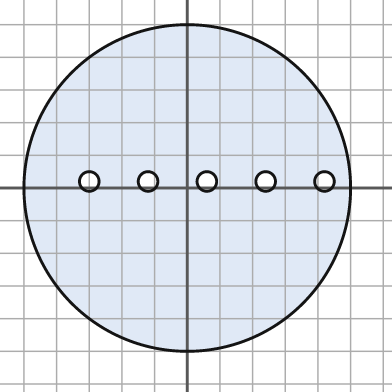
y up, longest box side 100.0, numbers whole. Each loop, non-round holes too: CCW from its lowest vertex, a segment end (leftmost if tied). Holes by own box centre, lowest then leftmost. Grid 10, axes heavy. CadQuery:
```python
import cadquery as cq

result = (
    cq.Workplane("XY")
    .moveTo(0.0, 0.0)
    .circle(50.0)
    .moveTo(-30.0, 2.0)
    .circle(3.0)
    .moveTo(-12.0, 2.0)
    .circle(3.0)
    .moveTo(6.0, 2.0)
    .circle(3.0)
    .moveTo(24.0, 2.0)
    .circle(3.0)
    .moveTo(42.0, 2.0)
    .circle(3.0)
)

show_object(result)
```